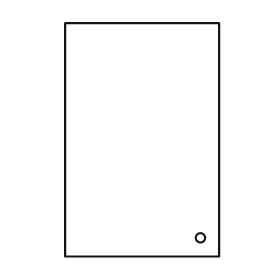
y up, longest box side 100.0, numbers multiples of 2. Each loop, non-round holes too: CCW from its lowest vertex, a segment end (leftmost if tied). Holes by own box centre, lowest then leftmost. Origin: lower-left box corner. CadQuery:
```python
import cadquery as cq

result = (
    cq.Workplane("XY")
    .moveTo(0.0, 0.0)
    .lineTo(66.0, 0.0)
    .lineTo(66.0, 100.0)
    .lineTo(0.0, 100.0)
    .close()
    .moveTo(58.0, 8.0)
    .circle(2.0)
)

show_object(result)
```